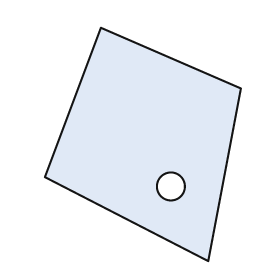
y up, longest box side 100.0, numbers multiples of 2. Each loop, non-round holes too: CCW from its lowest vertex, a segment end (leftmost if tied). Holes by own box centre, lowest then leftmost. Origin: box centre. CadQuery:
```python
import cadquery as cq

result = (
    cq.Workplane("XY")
    .moveTo(28.0, -50.0)
    .lineTo(42.0, 24.0)
    .lineTo(-18.0, 50.0)
    .lineTo(-42.0, -14.0)
    .close()
    .moveTo(12.0, -18.0)
    .circle(6.0)
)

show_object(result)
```